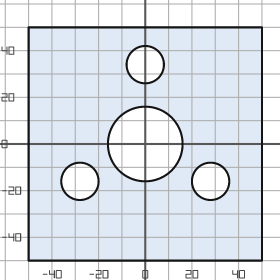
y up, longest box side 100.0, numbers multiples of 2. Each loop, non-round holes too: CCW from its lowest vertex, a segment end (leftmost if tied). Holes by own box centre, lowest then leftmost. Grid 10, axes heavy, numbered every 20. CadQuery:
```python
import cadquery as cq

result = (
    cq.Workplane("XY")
    .moveTo(-50.0, -50.0)
    .lineTo(50.0, -50.0)
    .lineTo(50.0, 50.0)
    .lineTo(-50.0, 50.0)
    .close()
    .moveTo(-28.0, -16.0)
    .circle(8.0)
    .moveTo(28.0, -16.0)
    .circle(8.0)
    .moveTo(0.0, 0.0)
    .circle(16.0)
    .moveTo(0.0, 34.0)
    .circle(8.0)
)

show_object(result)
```